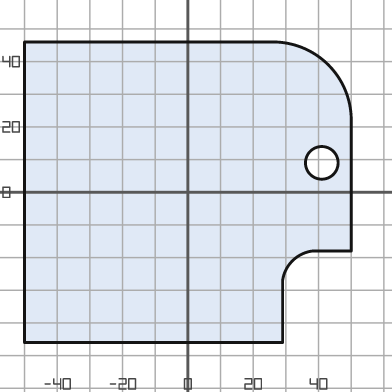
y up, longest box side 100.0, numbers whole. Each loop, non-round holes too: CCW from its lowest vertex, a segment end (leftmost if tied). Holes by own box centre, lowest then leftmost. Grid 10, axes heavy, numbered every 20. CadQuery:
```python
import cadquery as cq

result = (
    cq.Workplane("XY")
    .moveTo(-50.0, -46.0)
    .lineTo(29.0, -46.0)
    .lineTo(29.0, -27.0)
    .threePointArc((32.0, -21.0), (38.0, -18.0))
    .lineTo(50.0, -18.0)
    .lineTo(50.0, 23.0)
    .threePointArc((43.0, 39.0), (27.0, 46.0))
    .lineTo(-50.0, 46.0)
    .close()
    .moveTo(41.0, 9.0)
    .circle(5.0)
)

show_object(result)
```